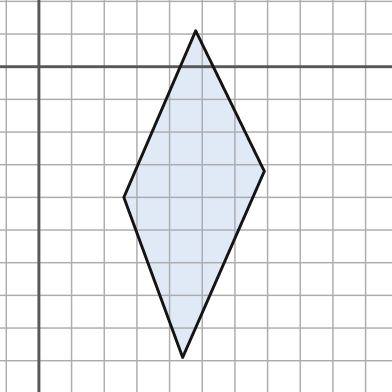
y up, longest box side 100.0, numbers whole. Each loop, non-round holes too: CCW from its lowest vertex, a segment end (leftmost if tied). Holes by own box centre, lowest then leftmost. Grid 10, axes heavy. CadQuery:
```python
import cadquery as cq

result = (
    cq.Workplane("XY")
    .moveTo(44.0, -89.0)
    .lineTo(69.0, -32.0)
    .lineTo(48.0, 11.0)
    .lineTo(26.0, -40.0)
    .close()
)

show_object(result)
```